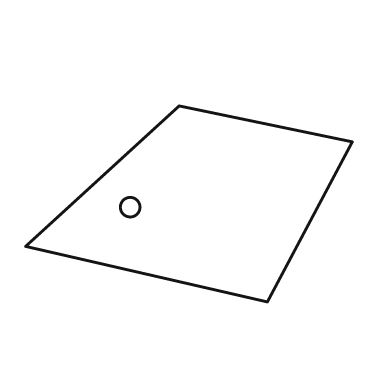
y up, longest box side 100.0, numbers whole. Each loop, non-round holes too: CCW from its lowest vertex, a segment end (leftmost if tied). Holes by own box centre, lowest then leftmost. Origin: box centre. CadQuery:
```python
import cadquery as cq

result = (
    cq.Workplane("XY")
    .moveTo(24.0, -30.0)
    .lineTo(50.0, 19.0)
    .lineTo(-3.0, 30.0)
    .lineTo(-50.0, -13.0)
    .close()
    .moveTo(-18.0, -1.0)
    .circle(3.0)
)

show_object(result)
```